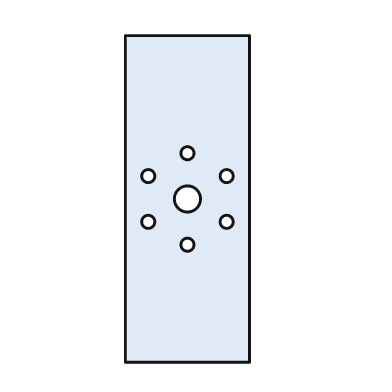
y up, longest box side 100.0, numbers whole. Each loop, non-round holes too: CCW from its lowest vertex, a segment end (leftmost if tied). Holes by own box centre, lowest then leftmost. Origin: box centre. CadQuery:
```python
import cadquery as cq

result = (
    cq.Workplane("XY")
    .moveTo(-19.0, -50.0)
    .lineTo(19.0, -50.0)
    .lineTo(19.0, 50.0)
    .lineTo(-19.0, 50.0)
    .close()
    .moveTo(0.0, -14.0)
    .circle(2.0)
    .moveTo(-12.0, -7.0)
    .circle(2.0)
    .moveTo(12.0, -7.0)
    .circle(2.0)
    .moveTo(0.0, 0.0)
    .circle(4.0)
    .moveTo(-12.0, 7.0)
    .circle(2.0)
    .moveTo(12.0, 7.0)
    .circle(2.0)
    .moveTo(0.0, 14.0)
    .circle(2.0)
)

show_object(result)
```